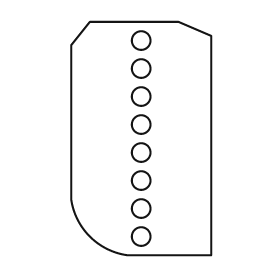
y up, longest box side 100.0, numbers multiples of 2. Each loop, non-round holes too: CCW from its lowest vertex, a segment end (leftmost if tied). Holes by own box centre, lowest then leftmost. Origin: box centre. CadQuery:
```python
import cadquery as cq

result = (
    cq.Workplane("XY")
    .moveTo(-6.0, -50.0)
    .lineTo(30.0, -50.0)
    .lineTo(30.0, 44.0)
    .lineTo(16.0, 50.0)
    .lineTo(-22.0, 50.0)
    .lineTo(-30.0, 40.0)
    .lineTo(-30.0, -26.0)
    .threePointArc((-22.0, -42.0), (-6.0, -50.0))
    .close()
    .moveTo(0.0, -42.0)
    .circle(4.0)
    .moveTo(0.0, -30.0)
    .circle(4.0)
    .moveTo(0.0, -18.0)
    .circle(4.0)
    .moveTo(0.0, -6.0)
    .circle(4.0)
    .moveTo(0.0, 6.0)
    .circle(4.0)
    .moveTo(0.0, 18.0)
    .circle(4.0)
    .moveTo(0.0, 30.0)
    .circle(4.0)
    .moveTo(0.0, 42.0)
    .circle(4.0)
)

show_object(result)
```